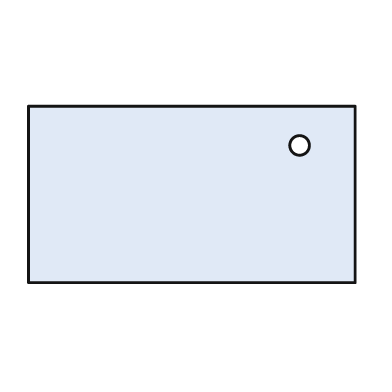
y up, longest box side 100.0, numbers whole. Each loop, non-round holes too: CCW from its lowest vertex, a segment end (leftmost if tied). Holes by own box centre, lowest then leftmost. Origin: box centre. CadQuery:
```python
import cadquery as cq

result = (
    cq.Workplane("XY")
    .moveTo(-50.0, -27.0)
    .lineTo(50.0, -27.0)
    .lineTo(50.0, 27.0)
    .lineTo(-50.0, 27.0)
    .close()
    .moveTo(33.0, 15.0)
    .circle(3.0)
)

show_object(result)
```